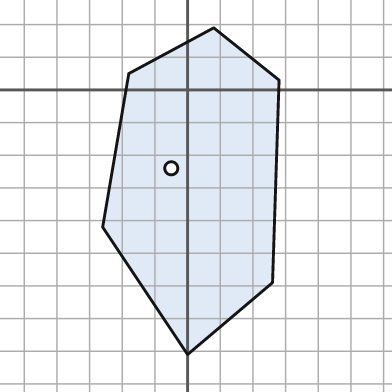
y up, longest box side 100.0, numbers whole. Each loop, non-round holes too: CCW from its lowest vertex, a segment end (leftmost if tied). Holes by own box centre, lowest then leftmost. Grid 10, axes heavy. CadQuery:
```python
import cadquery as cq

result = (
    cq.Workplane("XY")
    .moveTo(0.0, -81.0)
    .lineTo(26.0, -59.0)
    .lineTo(28.0, 3.0)
    .lineTo(8.0, 19.0)
    .lineTo(-18.0, 5.0)
    .lineTo(-26.0, -42.0)
    .close()
    .moveTo(-5.0, -24.0)
    .circle(2.0)
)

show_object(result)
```